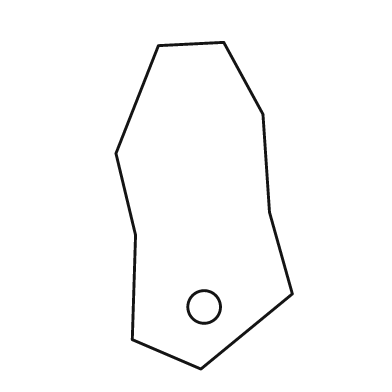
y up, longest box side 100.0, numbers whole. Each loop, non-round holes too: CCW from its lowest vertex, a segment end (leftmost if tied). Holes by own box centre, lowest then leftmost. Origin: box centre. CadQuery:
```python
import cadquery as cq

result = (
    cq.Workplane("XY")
    .moveTo(-1.0, -50.0)
    .lineTo(27.0, -27.0)
    .lineTo(20.0, -2.0)
    .lineTo(18.0, 28.0)
    .lineTo(6.0, 50.0)
    .lineTo(-14.0, 49.0)
    .lineTo(-27.0, 16.0)
    .lineTo(-21.0, -9.0)
    .lineTo(-22.0, -41.0)
    .close()
    .moveTo(0.0, -31.0)
    .circle(5.0)
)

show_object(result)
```